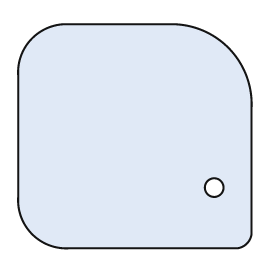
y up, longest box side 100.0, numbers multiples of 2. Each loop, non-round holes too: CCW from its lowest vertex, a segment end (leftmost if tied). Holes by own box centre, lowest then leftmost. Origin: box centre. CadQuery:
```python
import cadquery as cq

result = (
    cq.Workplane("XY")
    .moveTo(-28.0, -48.0)
    .lineTo(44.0, -48.0)
    .threePointArc((48.0, -46.0), (50.0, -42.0))
    .lineTo(50.0, 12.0)
    .threePointArc((40.0, 38.0), (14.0, 48.0))
    .lineTo(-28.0, 48.0)
    .threePointArc((-44.0, 42.0), (-50.0, 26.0))
    .lineTo(-50.0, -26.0)
    .threePointArc((-44.0, -42.0), (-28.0, -48.0))
    .close()
    .moveTo(34.0, -22.0)
    .circle(4.0)
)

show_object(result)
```